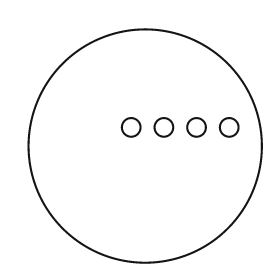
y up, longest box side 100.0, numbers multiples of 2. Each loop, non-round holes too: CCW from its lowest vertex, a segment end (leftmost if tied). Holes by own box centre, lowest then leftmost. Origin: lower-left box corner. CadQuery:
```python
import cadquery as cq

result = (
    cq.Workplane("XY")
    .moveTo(50.0, 50.0)
    .circle(50.0)
    .moveTo(44.0, 58.0)
    .circle(4.0)
    .moveTo(58.0, 58.0)
    .circle(4.0)
    .moveTo(72.0, 58.0)
    .circle(4.0)
    .moveTo(86.0, 58.0)
    .circle(4.0)
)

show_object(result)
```